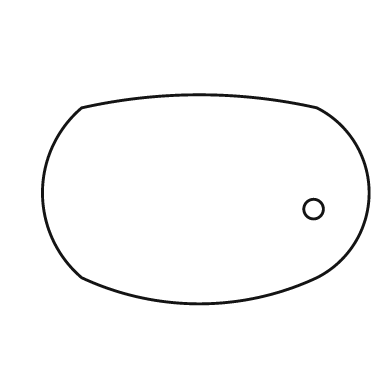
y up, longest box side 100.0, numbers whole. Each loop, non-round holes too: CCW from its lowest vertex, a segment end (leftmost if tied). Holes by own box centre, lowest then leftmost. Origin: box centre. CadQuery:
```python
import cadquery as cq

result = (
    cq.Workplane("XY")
    .moveTo(-38.0, -24.0)
    .threePointArc((-2.0, -32.0), (34.0, -24.0))
    .threePointArc((50.0, 2.0), (34.0, 28.0))
    .threePointArc((-2.0, 32.0), (-38.0, 28.0))
    .threePointArc((-50.0, 2.0), (-38.0, -24.0))
    .close()
    .moveTo(33.0, -3.0)
    .circle(3.0)
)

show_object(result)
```